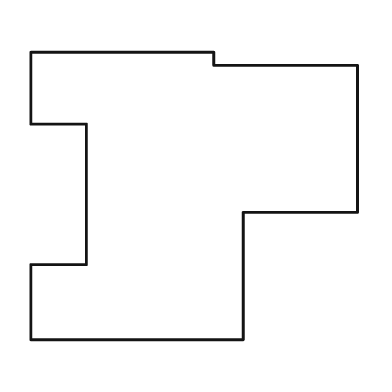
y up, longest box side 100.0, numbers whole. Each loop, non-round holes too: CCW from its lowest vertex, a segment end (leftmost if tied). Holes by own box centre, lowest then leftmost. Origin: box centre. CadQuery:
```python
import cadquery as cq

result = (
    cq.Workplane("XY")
    .moveTo(-50.0, -44.0)
    .lineTo(15.0, -44.0)
    .lineTo(15.0, -5.0)
    .lineTo(50.0, -5.0)
    .lineTo(50.0, 40.0)
    .lineTo(6.0, 40.0)
    .lineTo(6.0, 44.0)
    .lineTo(-50.0, 44.0)
    .lineTo(-50.0, 22.0)
    .lineTo(-33.0, 22.0)
    .lineTo(-33.0, -21.0)
    .lineTo(-50.0, -21.0)
    .close()
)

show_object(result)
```